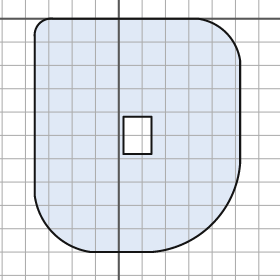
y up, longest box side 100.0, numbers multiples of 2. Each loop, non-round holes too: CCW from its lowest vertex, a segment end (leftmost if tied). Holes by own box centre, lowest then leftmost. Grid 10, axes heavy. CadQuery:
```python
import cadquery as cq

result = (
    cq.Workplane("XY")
    .moveTo(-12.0, -100.0)
    .lineTo(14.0, -100.0)
    .threePointArc((40.0, -88.0), (52.0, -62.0))
    .lineTo(52.0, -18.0)
    .threePointArc((46.0, -6.0), (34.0, 0.0))
    .lineTo(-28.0, 0.0)
    .threePointArc((-34.0, -2.0), (-36.0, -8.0))
    .lineTo(-36.0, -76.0)
    .threePointArc((-28.0, -92.0), (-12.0, -100.0))
    .close()
    .moveTo(2.0, -58.0)
    .lineTo(14.0, -58.0)
    .lineTo(14.0, -42.0)
    .lineTo(2.0, -42.0)
    .close()
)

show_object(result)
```